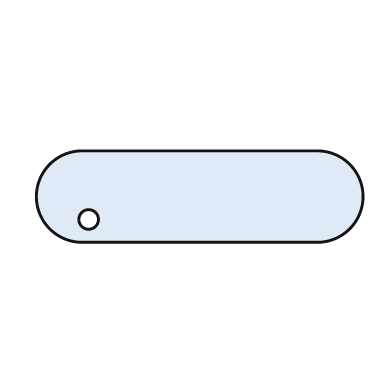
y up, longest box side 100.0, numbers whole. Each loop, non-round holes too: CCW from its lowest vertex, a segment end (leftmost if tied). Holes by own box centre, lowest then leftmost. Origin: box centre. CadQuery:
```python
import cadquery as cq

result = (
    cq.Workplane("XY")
    .moveTo(-36.0, -14.0)
    .lineTo(36.0, -14.0)
    .threePointArc((50.0, 0.0), (36.0, 14.0))
    .lineTo(-36.0, 14.0)
    .threePointArc((-50.0, 0.0), (-36.0, -14.0))
    .close()
    .moveTo(-34.0, -7.0)
    .circle(3.0)
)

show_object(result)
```